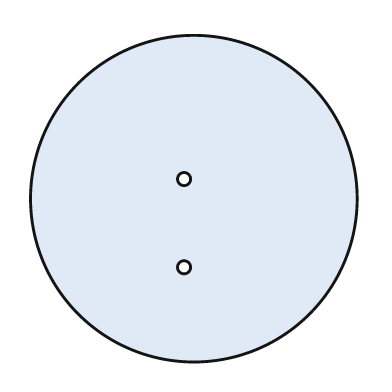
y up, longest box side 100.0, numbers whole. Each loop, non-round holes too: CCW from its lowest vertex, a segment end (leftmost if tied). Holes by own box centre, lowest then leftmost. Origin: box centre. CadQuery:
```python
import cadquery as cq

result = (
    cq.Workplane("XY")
    .moveTo(0.0, 0.0)
    .circle(50.0)
    .moveTo(-3.0, -21.0)
    .circle(2.0)
    .moveTo(-3.0, 6.0)
    .circle(2.0)
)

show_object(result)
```